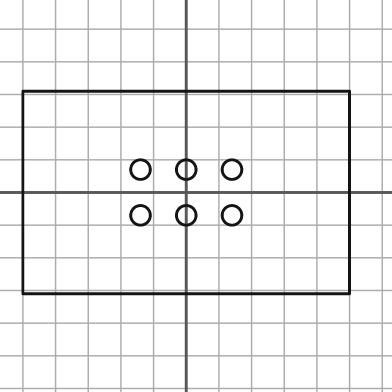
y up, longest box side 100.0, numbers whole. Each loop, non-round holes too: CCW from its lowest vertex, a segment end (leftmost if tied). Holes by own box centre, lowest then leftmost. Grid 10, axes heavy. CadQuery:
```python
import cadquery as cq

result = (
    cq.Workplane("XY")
    .moveTo(-50.0, -31.0)
    .lineTo(50.0, -31.0)
    .lineTo(50.0, 31.0)
    .lineTo(-50.0, 31.0)
    .close()
    .moveTo(-14.0, -7.0)
    .circle(3.0)
    .moveTo(0.0, -7.0)
    .circle(3.0)
    .moveTo(14.0, -7.0)
    .circle(3.0)
    .moveTo(-14.0, 7.0)
    .circle(3.0)
    .moveTo(0.0, 7.0)
    .circle(3.0)
    .moveTo(14.0, 7.0)
    .circle(3.0)
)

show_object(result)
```